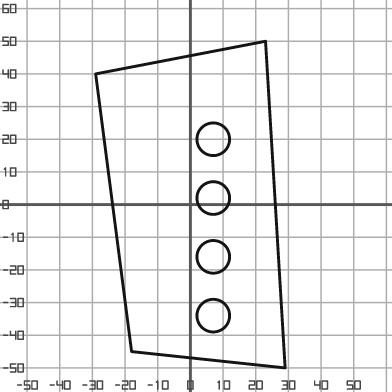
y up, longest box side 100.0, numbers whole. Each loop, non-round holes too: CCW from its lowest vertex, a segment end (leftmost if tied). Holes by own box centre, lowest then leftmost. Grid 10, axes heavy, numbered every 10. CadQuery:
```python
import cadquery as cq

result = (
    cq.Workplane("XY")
    .moveTo(29.0, -50.0)
    .lineTo(23.0, 50.0)
    .lineTo(-29.0, 40.0)
    .lineTo(-18.0, -45.0)
    .close()
    .moveTo(7.0, -34.0)
    .circle(5.0)
    .moveTo(7.0, -16.0)
    .circle(5.0)
    .moveTo(7.0, 2.0)
    .circle(5.0)
    .moveTo(7.0, 20.0)
    .circle(5.0)
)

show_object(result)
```